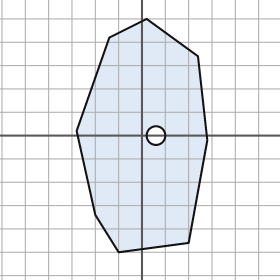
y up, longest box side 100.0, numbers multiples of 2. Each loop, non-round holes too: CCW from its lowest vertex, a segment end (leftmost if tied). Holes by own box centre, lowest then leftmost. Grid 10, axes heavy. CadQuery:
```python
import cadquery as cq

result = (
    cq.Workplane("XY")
    .moveTo(-10.0, -50.0)
    .lineTo(20.0, -46.0)
    .lineTo(28.0, -2.0)
    .lineTo(24.0, 34.0)
    .lineTo(2.0, 50.0)
    .lineTo(-14.0, 42.0)
    .lineTo(-28.0, 2.0)
    .lineTo(-20.0, -34.0)
    .close()
    .moveTo(6.0, 0.0)
    .circle(4.0)
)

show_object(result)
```